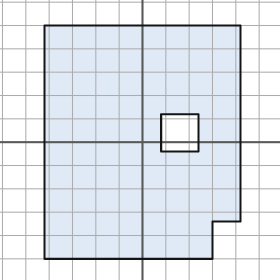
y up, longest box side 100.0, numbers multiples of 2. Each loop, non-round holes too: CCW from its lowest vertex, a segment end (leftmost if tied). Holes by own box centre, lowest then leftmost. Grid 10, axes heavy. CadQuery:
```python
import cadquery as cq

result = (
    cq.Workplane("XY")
    .moveTo(-42.0, -50.0)
    .lineTo(30.0, -50.0)
    .lineTo(30.0, -34.0)
    .lineTo(42.0, -34.0)
    .lineTo(42.0, 50.0)
    .lineTo(-42.0, 50.0)
    .close()
    .moveTo(8.0, -4.0)
    .lineTo(24.0, -4.0)
    .lineTo(24.0, 12.0)
    .lineTo(8.0, 12.0)
    .close()
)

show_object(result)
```